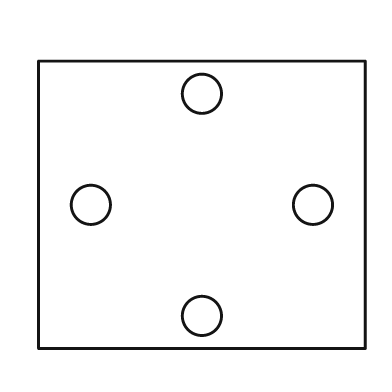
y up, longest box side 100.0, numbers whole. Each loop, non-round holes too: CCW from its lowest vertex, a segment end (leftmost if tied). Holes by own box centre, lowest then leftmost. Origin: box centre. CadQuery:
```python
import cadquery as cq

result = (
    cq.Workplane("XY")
    .moveTo(-50.0, -44.0)
    .lineTo(50.0, -44.0)
    .lineTo(50.0, 44.0)
    .lineTo(-50.0, 44.0)
    .close()
    .moveTo(0.0, -34.0)
    .circle(6.0)
    .moveTo(-34.0, 0.0)
    .circle(6.0)
    .moveTo(34.0, 0.0)
    .circle(6.0)
    .moveTo(0.0, 34.0)
    .circle(6.0)
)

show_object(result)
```